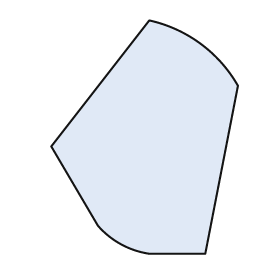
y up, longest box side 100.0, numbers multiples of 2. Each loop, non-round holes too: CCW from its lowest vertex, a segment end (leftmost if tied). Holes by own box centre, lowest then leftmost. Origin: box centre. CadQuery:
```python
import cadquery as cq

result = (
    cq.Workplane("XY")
    .moveTo(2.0, -50.0)
    .lineTo(26.0, -50.0)
    .lineTo(40.0, 22.0)
    .threePointArc((24.0, 40.0), (2.0, 50.0))
    .lineTo(-40.0, -4.0)
    .lineTo(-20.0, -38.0)
    .threePointArc((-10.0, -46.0), (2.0, -50.0))
    .close()
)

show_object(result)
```